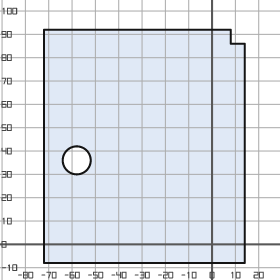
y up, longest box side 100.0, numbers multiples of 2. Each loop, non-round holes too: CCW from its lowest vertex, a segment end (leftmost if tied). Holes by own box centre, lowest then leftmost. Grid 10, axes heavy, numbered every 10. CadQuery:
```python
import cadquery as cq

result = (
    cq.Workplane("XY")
    .moveTo(-72.0, -8.0)
    .lineTo(14.0, -8.0)
    .lineTo(14.0, 86.0)
    .lineTo(8.0, 86.0)
    .lineTo(8.0, 92.0)
    .lineTo(-72.0, 92.0)
    .close()
    .moveTo(-58.0, 36.0)
    .circle(6.0)
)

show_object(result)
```